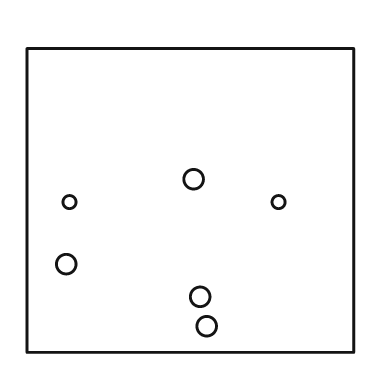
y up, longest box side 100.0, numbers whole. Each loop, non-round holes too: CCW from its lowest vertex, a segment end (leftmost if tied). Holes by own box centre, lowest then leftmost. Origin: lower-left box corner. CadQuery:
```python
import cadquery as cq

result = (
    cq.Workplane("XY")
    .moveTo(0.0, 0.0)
    .lineTo(100.0, 0.0)
    .lineTo(100.0, 93.0)
    .lineTo(0.0, 93.0)
    .close()
    .moveTo(55.0, 8.0)
    .circle(3.0)
    .moveTo(53.0, 17.0)
    .circle(3.0)
    .moveTo(12.0, 27.0)
    .circle(3.0)
    .moveTo(13.0, 46.0)
    .circle(2.0)
    .moveTo(77.0, 46.0)
    .circle(2.0)
    .moveTo(51.0, 53.0)
    .circle(3.0)
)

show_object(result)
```